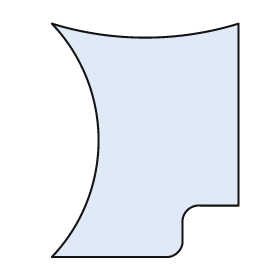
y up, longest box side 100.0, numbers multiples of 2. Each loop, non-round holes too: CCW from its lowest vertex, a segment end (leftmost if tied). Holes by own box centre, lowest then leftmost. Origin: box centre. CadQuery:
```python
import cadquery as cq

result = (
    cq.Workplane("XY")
    .moveTo(-40.0, -50.0)
    .lineTo(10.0, -50.0)
    .threePointArc((14.0, -48.0), (16.0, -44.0))
    .lineTo(16.0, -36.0)
    .threePointArc((18.0, -30.0), (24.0, -28.0))
    .lineTo(40.0, -28.0)
    .lineTo(40.0, 50.0)
    .threePointArc((0.0, 44.0), (-40.0, 50.0))
    .threePointArc((-20.0, 0.0), (-40.0, -50.0))
    .close()
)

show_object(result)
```